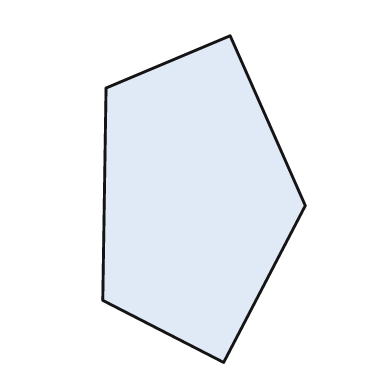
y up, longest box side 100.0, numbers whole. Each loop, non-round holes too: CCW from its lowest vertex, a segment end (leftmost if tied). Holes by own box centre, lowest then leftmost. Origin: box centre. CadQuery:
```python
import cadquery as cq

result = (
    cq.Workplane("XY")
    .moveTo(6.0, -50.0)
    .lineTo(31.0, -2.0)
    .lineTo(8.0, 50.0)
    .lineTo(-30.0, 34.0)
    .lineTo(-31.0, -31.0)
    .close()
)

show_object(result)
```